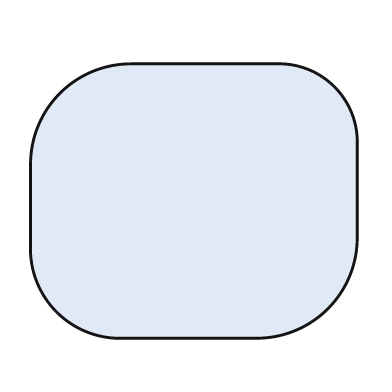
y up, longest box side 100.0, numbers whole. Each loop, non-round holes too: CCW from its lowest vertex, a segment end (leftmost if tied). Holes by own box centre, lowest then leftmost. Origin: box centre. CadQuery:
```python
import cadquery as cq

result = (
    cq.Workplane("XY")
    .moveTo(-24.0, -42.0)
    .lineTo(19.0, -42.0)
    .threePointArc((41.0, -33.0), (50.0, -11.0))
    .lineTo(50.0, 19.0)
    .threePointArc((43.0, 35.0), (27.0, 42.0))
    .lineTo(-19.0, 42.0)
    .threePointArc((-41.0, 33.0), (-50.0, 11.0))
    .lineTo(-50.0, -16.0)
    .threePointArc((-42.0, -34.0), (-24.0, -42.0))
    .close()
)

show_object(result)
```